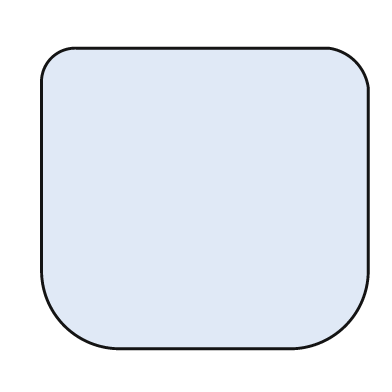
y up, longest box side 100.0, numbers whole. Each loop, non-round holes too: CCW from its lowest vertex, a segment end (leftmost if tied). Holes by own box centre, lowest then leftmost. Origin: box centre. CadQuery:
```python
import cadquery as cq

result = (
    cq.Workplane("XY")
    .moveTo(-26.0, -46.0)
    .lineTo(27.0, -46.0)
    .threePointArc((43.0, -39.0), (50.0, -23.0))
    .lineTo(50.0, 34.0)
    .threePointArc((46.0, 42.0), (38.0, 46.0))
    .lineTo(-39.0, 46.0)
    .threePointArc((-47.0, 43.0), (-50.0, 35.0))
    .lineTo(-50.0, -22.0)
    .threePointArc((-43.0, -39.0), (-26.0, -46.0))
    .close()
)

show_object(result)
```